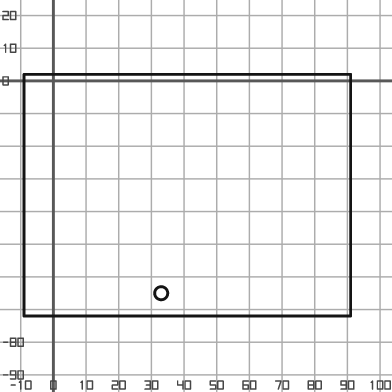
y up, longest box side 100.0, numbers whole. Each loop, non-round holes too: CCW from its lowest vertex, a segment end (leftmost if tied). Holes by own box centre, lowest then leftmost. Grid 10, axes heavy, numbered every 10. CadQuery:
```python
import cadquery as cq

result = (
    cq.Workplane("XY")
    .moveTo(-9.0, -72.0)
    .lineTo(91.0, -72.0)
    .lineTo(91.0, 2.0)
    .lineTo(-9.0, 2.0)
    .close()
    .moveTo(33.0, -65.0)
    .circle(2.0)
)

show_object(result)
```